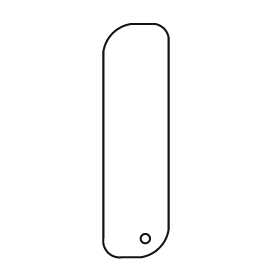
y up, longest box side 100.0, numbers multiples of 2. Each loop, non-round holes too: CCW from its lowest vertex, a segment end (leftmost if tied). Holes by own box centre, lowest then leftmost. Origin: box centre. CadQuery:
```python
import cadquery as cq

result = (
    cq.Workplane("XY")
    .moveTo(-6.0, -50.0)
    .lineTo(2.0, -50.0)
    .threePointArc((10.0, -46.0), (14.0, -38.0))
    .lineTo(14.0, 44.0)
    .threePointArc((12.0, 48.0), (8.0, 50.0))
    .lineTo(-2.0, 50.0)
    .threePointArc((-10.0, 46.0), (-14.0, 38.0))
    .lineTo(-14.0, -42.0)
    .threePointArc((-12.0, -48.0), (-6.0, -50.0))
    .close()
    .moveTo(4.0, -42.0)
    .circle(2.0)
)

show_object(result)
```